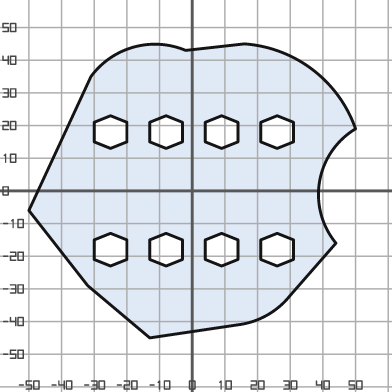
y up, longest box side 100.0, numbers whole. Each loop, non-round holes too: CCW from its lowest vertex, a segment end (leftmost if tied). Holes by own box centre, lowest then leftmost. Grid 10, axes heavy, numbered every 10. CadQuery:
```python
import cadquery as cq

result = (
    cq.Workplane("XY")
    .moveTo(-13.0, -45.0)
    .lineTo(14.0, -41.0)
    .threePointArc((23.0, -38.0), (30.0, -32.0))
    .lineTo(44.0, -16.0)
    .threePointArc((39.0, 3.0), (50.0, 19.0))
    .threePointArc((37.0, 37.0), (16.0, 45.0))
    .lineTo(-2.0, 43.0)
    .threePointArc((-18.0, 44.0), (-31.0, 35.0))
    .lineTo(-50.0, -6.0)
    .lineTo(-32.0, -29.0)
    .close()
    .moveTo(-25.0, -23.0)
    .lineTo(-20.0, -21.0)
    .lineTo(-20.0, -15.0)
    .lineTo(-25.0, -13.0)
    .lineTo(-30.0, -15.0)
    .lineTo(-30.0, -21.0)
    .close()
    .moveTo(-8.0, -23.0)
    .lineTo(-3.0, -21.0)
    .lineTo(-3.0, -15.0)
    .lineTo(-8.0, -13.0)
    .lineTo(-13.0, -15.0)
    .lineTo(-13.0, -21.0)
    .close()
    .moveTo(9.0, -23.0)
    .lineTo(14.0, -21.0)
    .lineTo(14.0, -15.0)
    .lineTo(9.0, -13.0)
    .lineTo(4.0, -15.0)
    .lineTo(4.0, -21.0)
    .close()
    .moveTo(26.0, -23.0)
    .lineTo(31.0, -21.0)
    .lineTo(31.0, -15.0)
    .lineTo(26.0, -13.0)
    .lineTo(21.0, -15.0)
    .lineTo(21.0, -21.0)
    .close()
    .moveTo(-25.0, 13.0)
    .lineTo(-20.0, 15.0)
    .lineTo(-20.0, 21.0)
    .lineTo(-25.0, 23.0)
    .lineTo(-30.0, 21.0)
    .lineTo(-30.0, 15.0)
    .close()
    .moveTo(-8.0, 13.0)
    .lineTo(-3.0, 15.0)
    .lineTo(-3.0, 21.0)
    .lineTo(-8.0, 23.0)
    .lineTo(-13.0, 21.0)
    .lineTo(-13.0, 15.0)
    .close()
    .moveTo(9.0, 13.0)
    .lineTo(14.0, 15.0)
    .lineTo(14.0, 21.0)
    .lineTo(9.0, 23.0)
    .lineTo(4.0, 21.0)
    .lineTo(4.0, 15.0)
    .close()
    .moveTo(26.0, 13.0)
    .lineTo(31.0, 15.0)
    .lineTo(31.0, 21.0)
    .lineTo(26.0, 23.0)
    .lineTo(21.0, 21.0)
    .lineTo(21.0, 15.0)
    .close()
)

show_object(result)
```